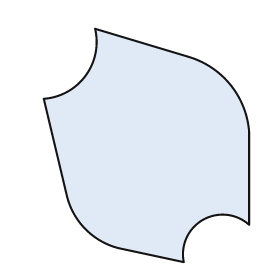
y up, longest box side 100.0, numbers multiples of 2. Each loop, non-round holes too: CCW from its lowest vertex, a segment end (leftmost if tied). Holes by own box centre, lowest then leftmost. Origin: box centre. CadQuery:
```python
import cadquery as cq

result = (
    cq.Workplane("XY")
    .moveTo(16.0, -50.0)
    .threePointArc((24.0, -32.0), (44.0, -34.0))
    .lineTo(44.0, 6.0)
    .threePointArc((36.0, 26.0), (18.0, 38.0))
    .lineTo(-22.0, 50.0)
    .threePointArc((-26.0, 30.0), (-44.0, 20.0))
    .lineTo(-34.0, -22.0)
    .threePointArc((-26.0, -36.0), (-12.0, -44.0))
    .close()
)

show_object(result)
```